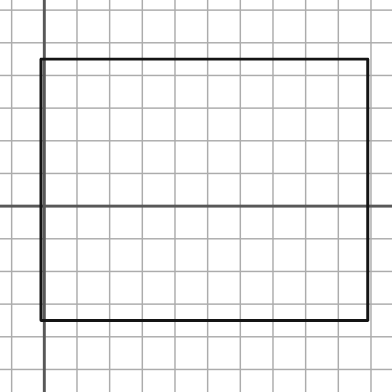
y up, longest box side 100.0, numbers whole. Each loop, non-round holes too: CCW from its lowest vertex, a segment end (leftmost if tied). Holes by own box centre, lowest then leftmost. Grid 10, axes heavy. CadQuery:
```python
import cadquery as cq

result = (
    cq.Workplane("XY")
    .moveTo(-1.0, -35.0)
    .lineTo(99.0, -35.0)
    .lineTo(99.0, 45.0)
    .lineTo(-1.0, 45.0)
    .close()
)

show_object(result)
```